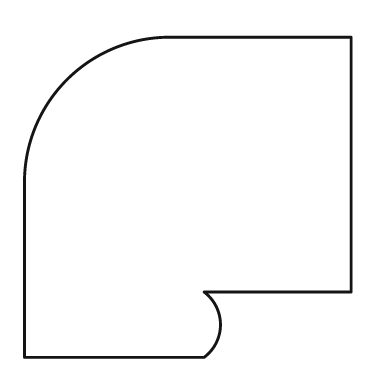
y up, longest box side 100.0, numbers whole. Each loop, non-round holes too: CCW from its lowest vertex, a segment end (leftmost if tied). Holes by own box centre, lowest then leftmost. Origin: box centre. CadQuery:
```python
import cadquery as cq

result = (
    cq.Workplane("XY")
    .moveTo(-50.0, -49.0)
    .lineTo(5.0, -49.0)
    .threePointArc((10.0, -39.0), (5.0, -29.0))
    .lineTo(50.0, -29.0)
    .lineTo(50.0, 49.0)
    .lineTo(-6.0, 49.0)
    .threePointArc((-37.0, 36.0), (-50.0, 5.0))
    .close()
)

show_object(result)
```